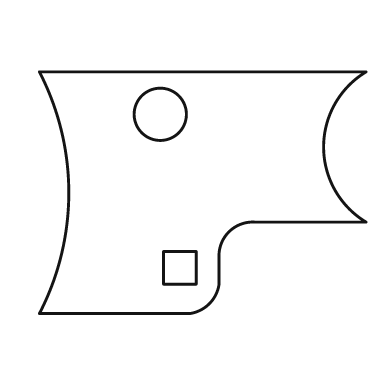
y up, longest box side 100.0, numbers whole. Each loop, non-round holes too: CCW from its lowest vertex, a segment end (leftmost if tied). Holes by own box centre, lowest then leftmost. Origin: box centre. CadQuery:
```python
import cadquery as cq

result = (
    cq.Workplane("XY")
    .moveTo(-50.0, -37.0)
    .lineTo(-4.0, -37.0)
    .threePointArc((2.0, -34.0), (5.0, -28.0))
    .lineTo(5.0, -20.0)
    .threePointArc((8.0, -12.0), (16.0, -9.0))
    .lineTo(50.0, -9.0)
    .threePointArc((37.0, 14.0), (50.0, 37.0))
    .lineTo(-50.0, 37.0)
    .threePointArc((-41.0, 0.0), (-50.0, -37.0))
    .close()
    .moveTo(-12.0, -28.0)
    .lineTo(-2.0, -28.0)
    .lineTo(-2.0, -18.0)
    .lineTo(-12.0, -18.0)
    .close()
    .moveTo(-13.0, 24.0)
    .circle(8.0)
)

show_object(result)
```